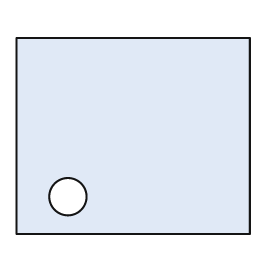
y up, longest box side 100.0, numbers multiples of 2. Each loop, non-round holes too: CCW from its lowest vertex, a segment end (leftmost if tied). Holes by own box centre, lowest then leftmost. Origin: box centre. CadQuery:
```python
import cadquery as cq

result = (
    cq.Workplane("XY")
    .moveTo(-50.0, -42.0)
    .lineTo(50.0, -42.0)
    .lineTo(50.0, 42.0)
    .lineTo(-50.0, 42.0)
    .close()
    .moveTo(-28.0, -26.0)
    .circle(8.0)
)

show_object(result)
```